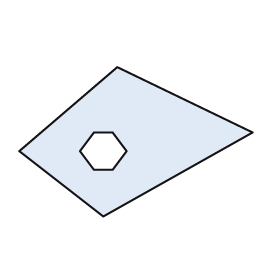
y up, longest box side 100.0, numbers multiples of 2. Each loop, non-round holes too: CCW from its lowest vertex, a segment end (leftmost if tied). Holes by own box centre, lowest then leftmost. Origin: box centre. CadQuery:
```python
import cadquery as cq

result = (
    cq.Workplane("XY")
    .moveTo(-14.0, -32.0)
    .lineTo(50.0, 4.0)
    .lineTo(-8.0, 32.0)
    .lineTo(-50.0, -4.0)
    .close()
    .moveTo(-18.0, -12.0)
    .lineTo(-10.0, -12.0)
    .lineTo(-4.0, -4.0)
    .lineTo(-10.0, 4.0)
    .lineTo(-18.0, 4.0)
    .lineTo(-24.0, -4.0)
    .close()
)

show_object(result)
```